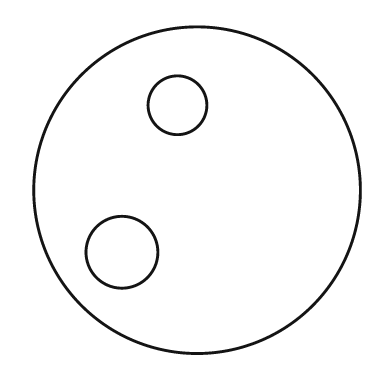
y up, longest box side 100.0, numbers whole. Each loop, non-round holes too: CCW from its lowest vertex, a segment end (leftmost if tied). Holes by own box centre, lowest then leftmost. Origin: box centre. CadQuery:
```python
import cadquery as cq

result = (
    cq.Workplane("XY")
    .moveTo(0.0, 0.0)
    .circle(50.0)
    .moveTo(-23.0, -19.0)
    .circle(11.0)
    .moveTo(-6.0, 26.0)
    .circle(9.0)
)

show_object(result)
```